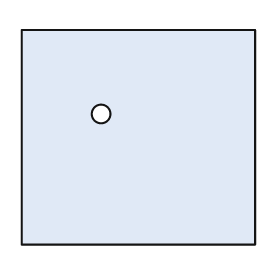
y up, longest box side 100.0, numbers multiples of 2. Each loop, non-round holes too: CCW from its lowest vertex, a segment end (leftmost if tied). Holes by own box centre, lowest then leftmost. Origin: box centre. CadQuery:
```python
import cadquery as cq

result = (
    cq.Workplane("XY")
    .moveTo(-50.0, -46.0)
    .lineTo(50.0, -46.0)
    .lineTo(50.0, 46.0)
    .lineTo(-50.0, 46.0)
    .close()
    .moveTo(-16.0, 10.0)
    .circle(4.0)
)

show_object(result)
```